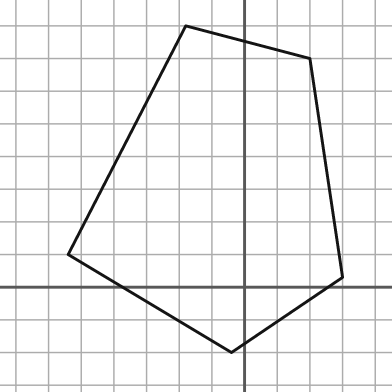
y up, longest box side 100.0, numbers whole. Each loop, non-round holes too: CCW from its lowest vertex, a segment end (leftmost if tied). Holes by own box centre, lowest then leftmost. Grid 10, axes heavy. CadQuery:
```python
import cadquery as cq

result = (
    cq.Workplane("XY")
    .moveTo(-4.0, -20.0)
    .lineTo(30.0, 3.0)
    .lineTo(20.0, 70.0)
    .lineTo(-18.0, 80.0)
    .lineTo(-54.0, 10.0)
    .close()
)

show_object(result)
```